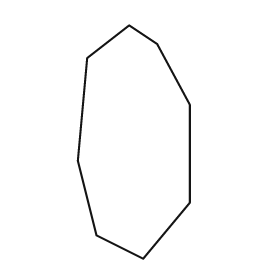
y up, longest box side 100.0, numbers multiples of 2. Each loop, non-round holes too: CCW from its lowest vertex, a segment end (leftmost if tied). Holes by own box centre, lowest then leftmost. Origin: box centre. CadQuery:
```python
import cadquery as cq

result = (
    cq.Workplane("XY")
    .moveTo(4.0, -50.0)
    .lineTo(24.0, -26.0)
    .lineTo(24.0, 16.0)
    .lineTo(10.0, 42.0)
    .lineTo(-2.0, 50.0)
    .lineTo(-20.0, 36.0)
    .lineTo(-24.0, -8.0)
    .lineTo(-16.0, -40.0)
    .close()
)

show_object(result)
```